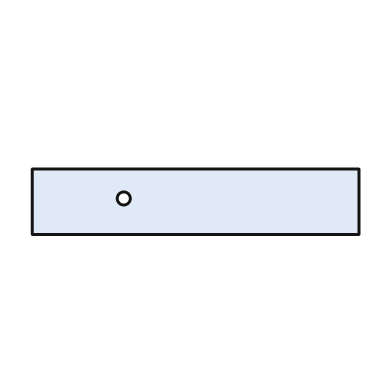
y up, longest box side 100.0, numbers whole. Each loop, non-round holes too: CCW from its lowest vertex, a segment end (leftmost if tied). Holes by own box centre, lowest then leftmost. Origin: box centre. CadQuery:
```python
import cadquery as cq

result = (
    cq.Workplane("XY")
    .moveTo(-50.0, -10.0)
    .lineTo(50.0, -10.0)
    .lineTo(50.0, 10.0)
    .lineTo(-50.0, 10.0)
    .close()
    .moveTo(-22.0, 1.0)
    .circle(2.0)
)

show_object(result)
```